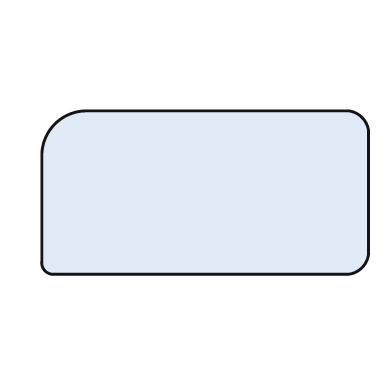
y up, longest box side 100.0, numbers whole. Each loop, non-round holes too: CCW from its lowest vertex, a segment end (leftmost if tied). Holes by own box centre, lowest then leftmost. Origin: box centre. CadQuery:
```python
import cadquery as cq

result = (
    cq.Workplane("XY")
    .moveTo(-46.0, -25.0)
    .lineTo(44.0, -25.0)
    .threePointArc((48.0, -23.0), (50.0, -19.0))
    .lineTo(50.0, 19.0)
    .threePointArc((48.0, 23.0), (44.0, 25.0))
    .lineTo(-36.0, 25.0)
    .threePointArc((-46.0, 21.0), (-50.0, 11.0))
    .lineTo(-50.0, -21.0)
    .threePointArc((-49.0, -24.0), (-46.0, -25.0))
    .close()
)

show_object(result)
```